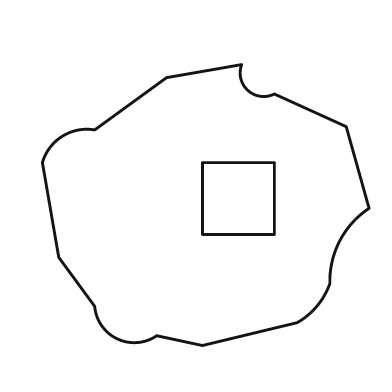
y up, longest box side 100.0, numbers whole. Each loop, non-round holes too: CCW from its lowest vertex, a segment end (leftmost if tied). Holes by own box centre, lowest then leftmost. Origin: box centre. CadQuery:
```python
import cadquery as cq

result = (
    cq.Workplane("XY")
    .moveTo(-1.0, -43.0)
    .lineTo(28.0, -36.0)
    .threePointArc((34.0, -31.0), (38.0, -24.0))
    .threePointArc((41.0, -11.0), (50.0, -1.0))
    .lineTo(43.0, 24.0)
    .lineTo(21.0, 34.0)
    .threePointArc((13.0, 35.0), (11.0, 43.0))
    .lineTo(-12.0, 39.0)
    .lineTo(-34.0, 23.0)
    .threePointArc((-44.0, 21.0), (-50.0, 13.0))
    .lineTo(-45.0, -16.0)
    .lineTo(-34.0, -31.0)
    .threePointArc((-27.0, -41.0), (-15.0, -40.0))
    .close()
    .moveTo(-1.0, -9.0)
    .lineTo(21.0, -9.0)
    .lineTo(21.0, 13.0)
    .lineTo(-1.0, 13.0)
    .close()
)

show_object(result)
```